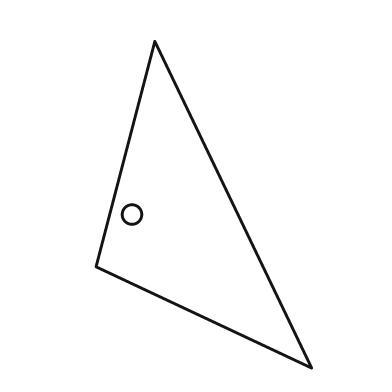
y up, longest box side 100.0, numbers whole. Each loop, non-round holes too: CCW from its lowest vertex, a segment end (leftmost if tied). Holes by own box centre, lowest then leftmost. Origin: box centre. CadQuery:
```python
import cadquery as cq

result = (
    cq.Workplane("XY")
    .moveTo(33.0, -50.0)
    .lineTo(-15.0, 50.0)
    .lineTo(-33.0, -19.0)
    .close()
    .moveTo(-22.0, -3.0)
    .circle(3.0)
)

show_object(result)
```